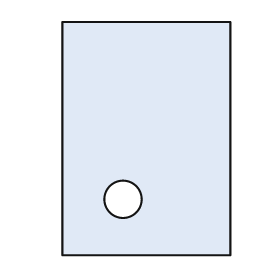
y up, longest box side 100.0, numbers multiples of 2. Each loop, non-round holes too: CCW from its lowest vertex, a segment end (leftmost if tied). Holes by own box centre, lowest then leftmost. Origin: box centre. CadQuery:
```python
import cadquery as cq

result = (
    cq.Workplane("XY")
    .moveTo(-36.0, -50.0)
    .lineTo(36.0, -50.0)
    .lineTo(36.0, 50.0)
    .lineTo(-36.0, 50.0)
    .close()
    .moveTo(-10.0, -26.0)
    .circle(8.0)
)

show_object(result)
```